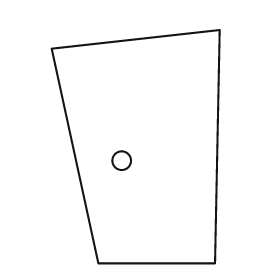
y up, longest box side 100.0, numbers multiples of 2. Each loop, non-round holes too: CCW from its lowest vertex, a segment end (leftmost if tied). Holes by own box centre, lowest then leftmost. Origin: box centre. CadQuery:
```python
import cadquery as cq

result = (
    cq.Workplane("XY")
    .moveTo(-16.0, -50.0)
    .lineTo(34.0, -50.0)
    .lineTo(36.0, 50.0)
    .lineTo(-36.0, 42.0)
    .close()
    .moveTo(-6.0, -6.0)
    .circle(4.0)
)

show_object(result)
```